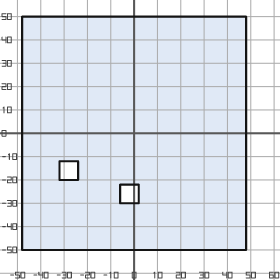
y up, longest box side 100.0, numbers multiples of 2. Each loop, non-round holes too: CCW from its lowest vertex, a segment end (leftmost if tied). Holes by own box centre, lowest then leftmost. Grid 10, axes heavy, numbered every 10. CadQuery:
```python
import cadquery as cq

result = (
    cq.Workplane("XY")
    .moveTo(-48.0, -50.0)
    .lineTo(48.0, -50.0)
    .lineTo(48.0, 50.0)
    .lineTo(-48.0, 50.0)
    .close()
    .moveTo(-6.0, -30.0)
    .lineTo(2.0, -30.0)
    .lineTo(2.0, -22.0)
    .lineTo(-6.0, -22.0)
    .close()
    .moveTo(-32.0, -20.0)
    .lineTo(-24.0, -20.0)
    .lineTo(-24.0, -12.0)
    .lineTo(-32.0, -12.0)
    .close()
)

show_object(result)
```